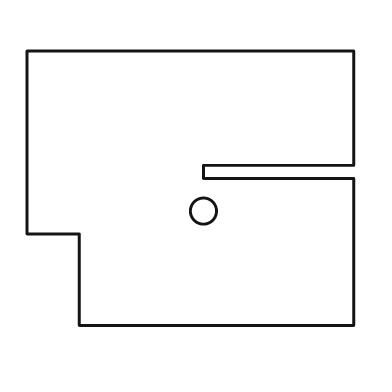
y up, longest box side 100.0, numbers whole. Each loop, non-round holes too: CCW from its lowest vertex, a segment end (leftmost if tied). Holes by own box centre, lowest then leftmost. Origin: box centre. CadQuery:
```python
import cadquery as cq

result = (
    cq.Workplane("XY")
    .moveTo(-34.0, -42.0)
    .lineTo(50.0, -42.0)
    .lineTo(50.0, 3.0)
    .lineTo(4.0, 3.0)
    .lineTo(4.0, 7.0)
    .lineTo(50.0, 7.0)
    .lineTo(50.0, 42.0)
    .lineTo(-50.0, 42.0)
    .lineTo(-50.0, -14.0)
    .lineTo(-34.0, -14.0)
    .close()
    .moveTo(4.0, -7.0)
    .circle(4.0)
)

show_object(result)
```